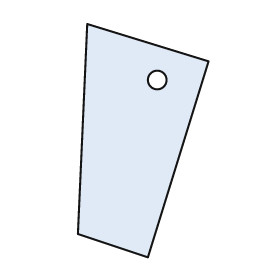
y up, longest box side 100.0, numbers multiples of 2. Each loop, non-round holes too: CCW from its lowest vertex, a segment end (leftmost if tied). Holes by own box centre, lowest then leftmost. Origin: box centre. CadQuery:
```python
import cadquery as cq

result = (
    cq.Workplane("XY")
    .moveTo(2.0, -50.0)
    .lineTo(28.0, 34.0)
    .lineTo(-24.0, 50.0)
    .lineTo(-28.0, -40.0)
    .close()
    .moveTo(6.0, 26.0)
    .circle(4.0)
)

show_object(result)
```